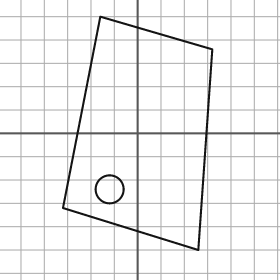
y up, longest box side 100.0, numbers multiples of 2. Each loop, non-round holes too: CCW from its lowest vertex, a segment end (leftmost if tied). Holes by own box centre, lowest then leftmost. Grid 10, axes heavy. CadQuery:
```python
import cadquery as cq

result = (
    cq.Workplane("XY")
    .moveTo(26.0, -50.0)
    .lineTo(32.0, 36.0)
    .lineTo(-16.0, 50.0)
    .lineTo(-32.0, -32.0)
    .close()
    .moveTo(-12.0, -24.0)
    .circle(6.0)
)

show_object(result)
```